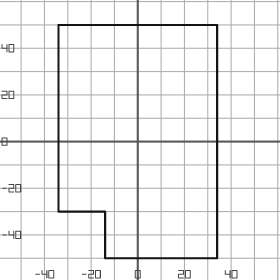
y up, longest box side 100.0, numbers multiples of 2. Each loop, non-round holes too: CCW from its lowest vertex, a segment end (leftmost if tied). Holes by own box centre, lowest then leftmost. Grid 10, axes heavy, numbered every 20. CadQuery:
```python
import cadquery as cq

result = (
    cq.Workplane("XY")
    .moveTo(-14.0, -50.0)
    .lineTo(34.0, -50.0)
    .lineTo(34.0, 50.0)
    .lineTo(-34.0, 50.0)
    .lineTo(-34.0, -30.0)
    .lineTo(-14.0, -30.0)
    .close()
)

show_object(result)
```